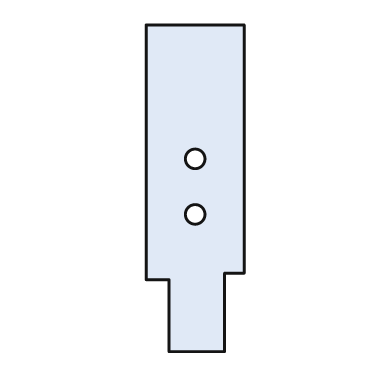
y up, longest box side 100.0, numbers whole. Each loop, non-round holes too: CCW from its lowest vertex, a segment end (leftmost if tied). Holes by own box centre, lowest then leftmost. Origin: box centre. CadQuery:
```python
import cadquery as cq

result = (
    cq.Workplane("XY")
    .moveTo(-8.0, -50.0)
    .lineTo(9.0, -50.0)
    .lineTo(9.0, -26.0)
    .lineTo(15.0, -26.0)
    .lineTo(15.0, 50.0)
    .lineTo(-15.0, 50.0)
    .lineTo(-15.0, -28.0)
    .lineTo(-8.0, -28.0)
    .close()
    .moveTo(0.0, -8.0)
    .circle(3.0)
    .moveTo(0.0, 9.0)
    .circle(3.0)
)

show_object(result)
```